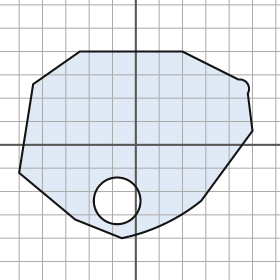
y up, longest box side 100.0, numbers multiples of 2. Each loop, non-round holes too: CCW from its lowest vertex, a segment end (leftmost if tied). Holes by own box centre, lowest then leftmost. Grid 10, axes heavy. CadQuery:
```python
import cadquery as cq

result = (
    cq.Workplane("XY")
    .moveTo(-6.0, -40.0)
    .threePointArc((12.0, -34.0), (28.0, -24.0))
    .lineTo(50.0, 6.0)
    .lineTo(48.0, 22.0)
    .threePointArc((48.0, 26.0), (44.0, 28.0))
    .lineTo(20.0, 40.0)
    .lineTo(-24.0, 40.0)
    .lineTo(-44.0, 26.0)
    .lineTo(-50.0, -12.0)
    .lineTo(-26.0, -32.0)
    .close()
    .moveTo(-8.0, -24.0)
    .circle(10.0)
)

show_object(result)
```